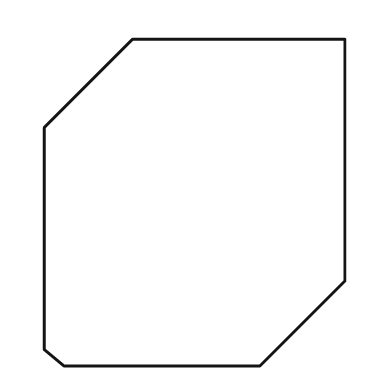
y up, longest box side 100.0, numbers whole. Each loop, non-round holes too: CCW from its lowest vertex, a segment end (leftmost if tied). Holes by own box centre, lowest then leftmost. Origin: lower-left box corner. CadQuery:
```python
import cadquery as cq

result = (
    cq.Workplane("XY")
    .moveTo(6.0, 0.0)
    .lineTo(66.0, 0.0)
    .lineTo(92.0, 26.0)
    .lineTo(92.0, 100.0)
    .lineTo(27.0, 100.0)
    .lineTo(0.0, 73.0)
    .lineTo(0.0, 5.0)
    .close()
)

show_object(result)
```